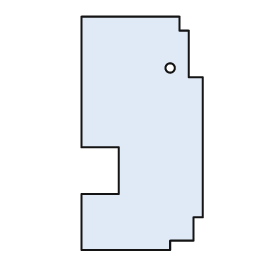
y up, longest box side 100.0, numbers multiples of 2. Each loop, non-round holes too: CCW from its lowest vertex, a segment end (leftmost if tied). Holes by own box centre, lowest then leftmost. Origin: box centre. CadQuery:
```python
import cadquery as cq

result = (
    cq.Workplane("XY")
    .moveTo(-26.0, -50.0)
    .lineTo(12.0, -50.0)
    .lineTo(12.0, -46.0)
    .lineTo(22.0, -46.0)
    .lineTo(22.0, -36.0)
    .lineTo(26.0, -36.0)
    .lineTo(26.0, 24.0)
    .lineTo(20.0, 24.0)
    .lineTo(20.0, 44.0)
    .lineTo(16.0, 44.0)
    .lineTo(16.0, 50.0)
    .lineTo(-26.0, 50.0)
    .lineTo(-26.0, -6.0)
    .lineTo(-10.0, -6.0)
    .lineTo(-10.0, -26.0)
    .lineTo(-26.0, -26.0)
    .close()
    .moveTo(12.0, 28.0)
    .circle(2.0)
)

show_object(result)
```